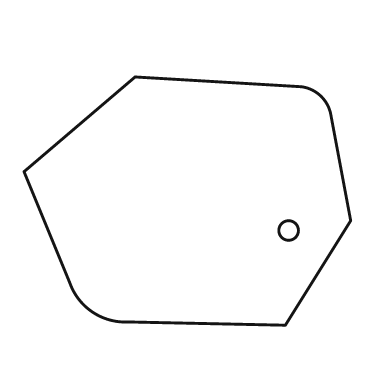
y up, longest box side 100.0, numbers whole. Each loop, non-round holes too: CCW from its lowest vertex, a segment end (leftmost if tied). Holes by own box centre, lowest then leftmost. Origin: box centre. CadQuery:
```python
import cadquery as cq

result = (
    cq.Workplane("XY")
    .moveTo(30.0, -38.0)
    .lineTo(50.0, -6.0)
    .lineTo(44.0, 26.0)
    .threePointArc((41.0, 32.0), (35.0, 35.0))
    .lineTo(-16.0, 38.0)
    .lineTo(-50.0, 9.0)
    .lineTo(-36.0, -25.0)
    .threePointArc((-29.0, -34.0), (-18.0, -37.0))
    .close()
    .moveTo(31.0, -9.0)
    .circle(3.0)
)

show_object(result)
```